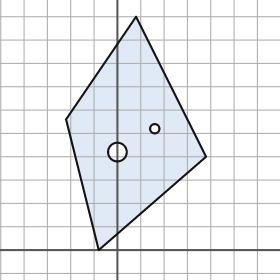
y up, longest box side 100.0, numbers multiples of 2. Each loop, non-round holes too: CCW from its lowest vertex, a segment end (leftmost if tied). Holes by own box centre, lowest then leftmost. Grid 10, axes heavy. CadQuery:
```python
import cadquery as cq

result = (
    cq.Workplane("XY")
    .moveTo(-8.0, 0.0)
    .lineTo(38.0, 40.0)
    .lineTo(8.0, 100.0)
    .lineTo(-22.0, 56.0)
    .close()
    .moveTo(0.0, 42.0)
    .circle(4.0)
    .moveTo(16.0, 52.0)
    .circle(2.0)
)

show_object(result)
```